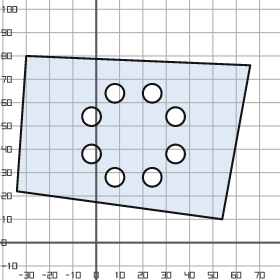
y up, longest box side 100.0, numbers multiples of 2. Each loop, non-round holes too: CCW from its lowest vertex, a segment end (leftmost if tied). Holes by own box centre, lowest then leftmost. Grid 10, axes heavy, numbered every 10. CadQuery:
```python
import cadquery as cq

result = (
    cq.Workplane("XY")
    .moveTo(54.0, 10.0)
    .lineTo(66.0, 76.0)
    .lineTo(-30.0, 80.0)
    .lineTo(-34.0, 22.0)
    .close()
    .moveTo(8.0, 28.0)
    .circle(4.0)
    .moveTo(24.0, 28.0)
    .circle(4.0)
    .moveTo(-2.0, 38.0)
    .circle(4.0)
    .moveTo(34.0, 38.0)
    .circle(4.0)
    .moveTo(-2.0, 54.0)
    .circle(4.0)
    .moveTo(34.0, 54.0)
    .circle(4.0)
    .moveTo(8.0, 64.0)
    .circle(4.0)
    .moveTo(24.0, 64.0)
    .circle(4.0)
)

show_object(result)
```